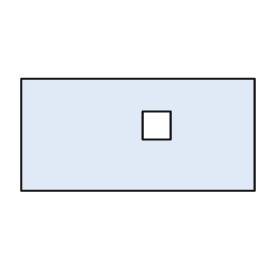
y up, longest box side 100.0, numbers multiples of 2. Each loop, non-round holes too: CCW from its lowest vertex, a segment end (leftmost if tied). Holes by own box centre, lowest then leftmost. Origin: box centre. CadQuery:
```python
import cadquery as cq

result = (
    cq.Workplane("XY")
    .moveTo(-50.0, -24.0)
    .lineTo(50.0, -24.0)
    .lineTo(50.0, 24.0)
    .lineTo(-50.0, 24.0)
    .close()
    .moveTo(2.0, -2.0)
    .lineTo(14.0, -2.0)
    .lineTo(14.0, 10.0)
    .lineTo(2.0, 10.0)
    .close()
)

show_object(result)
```